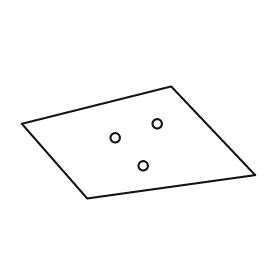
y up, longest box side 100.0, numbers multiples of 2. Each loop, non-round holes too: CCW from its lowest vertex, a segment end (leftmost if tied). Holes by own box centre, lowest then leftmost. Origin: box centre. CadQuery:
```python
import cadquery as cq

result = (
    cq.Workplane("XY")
    .moveTo(-22.0, -24.0)
    .lineTo(50.0, -14.0)
    .lineTo(14.0, 24.0)
    .lineTo(-50.0, 8.0)
    .close()
    .moveTo(2.0, -10.0)
    .circle(2.0)
    .moveTo(-10.0, 2.0)
    .circle(2.0)
    .moveTo(8.0, 8.0)
    .circle(2.0)
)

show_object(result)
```